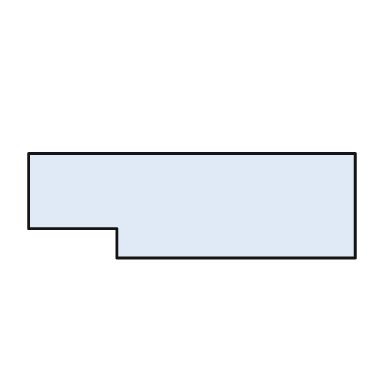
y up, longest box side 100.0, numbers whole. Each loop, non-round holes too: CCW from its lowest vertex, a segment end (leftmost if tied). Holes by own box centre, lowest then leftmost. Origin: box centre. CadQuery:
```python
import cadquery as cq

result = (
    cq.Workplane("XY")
    .moveTo(-23.0, -16.0)
    .lineTo(50.0, -16.0)
    .lineTo(50.0, 16.0)
    .lineTo(-50.0, 16.0)
    .lineTo(-50.0, -7.0)
    .lineTo(-23.0, -7.0)
    .close()
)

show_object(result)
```